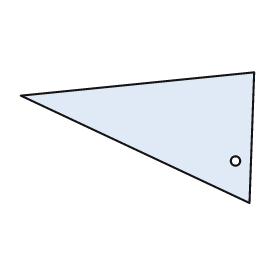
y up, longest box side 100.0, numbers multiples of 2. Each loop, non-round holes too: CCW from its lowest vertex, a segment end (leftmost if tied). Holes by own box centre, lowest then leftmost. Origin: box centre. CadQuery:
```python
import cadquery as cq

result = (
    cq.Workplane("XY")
    .moveTo(48.0, -28.0)
    .lineTo(50.0, 28.0)
    .lineTo(-50.0, 18.0)
    .close()
    .moveTo(42.0, -10.0)
    .circle(2.0)
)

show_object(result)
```